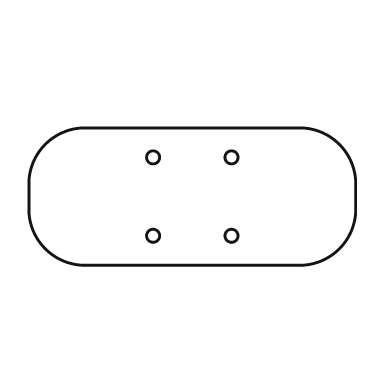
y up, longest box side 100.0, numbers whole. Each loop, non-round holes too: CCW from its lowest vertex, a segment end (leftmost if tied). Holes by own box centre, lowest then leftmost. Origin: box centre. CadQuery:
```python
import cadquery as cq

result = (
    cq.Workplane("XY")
    .moveTo(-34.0, -21.0)
    .lineTo(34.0, -21.0)
    .threePointArc((45.0, -16.0), (50.0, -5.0))
    .lineTo(50.0, 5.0)
    .threePointArc((45.0, 16.0), (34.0, 21.0))
    .lineTo(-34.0, 21.0)
    .threePointArc((-45.0, 16.0), (-50.0, 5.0))
    .lineTo(-50.0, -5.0)
    .threePointArc((-45.0, -16.0), (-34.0, -21.0))
    .close()
    .moveTo(-12.0, -12.0)
    .circle(2.0)
    .moveTo(12.0, -12.0)
    .circle(2.0)
    .moveTo(-12.0, 12.0)
    .circle(2.0)
    .moveTo(12.0, 12.0)
    .circle(2.0)
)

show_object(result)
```